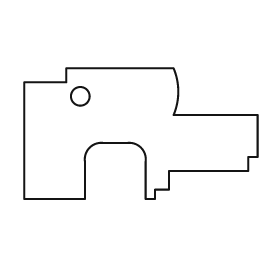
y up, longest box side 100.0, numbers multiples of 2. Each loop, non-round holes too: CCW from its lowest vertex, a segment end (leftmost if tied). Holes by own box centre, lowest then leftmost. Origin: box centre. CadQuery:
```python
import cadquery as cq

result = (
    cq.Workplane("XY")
    .moveTo(-50.0, -28.0)
    .lineTo(-24.0, -28.0)
    .lineTo(-24.0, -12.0)
    .threePointArc((-22.0, -6.0), (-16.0, -4.0))
    .lineTo(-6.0, -4.0)
    .threePointArc((0.0, -6.0), (2.0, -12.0))
    .lineTo(2.0, -28.0)
    .lineTo(6.0, -28.0)
    .lineTo(6.0, -24.0)
    .lineTo(12.0, -24.0)
    .lineTo(12.0, -16.0)
    .lineTo(46.0, -16.0)
    .lineTo(46.0, -10.0)
    .lineTo(50.0, -10.0)
    .lineTo(50.0, 8.0)
    .lineTo(14.0, 8.0)
    .threePointArc((16.0, 18.0), (14.0, 28.0))
    .lineTo(-32.0, 28.0)
    .lineTo(-32.0, 22.0)
    .lineTo(-50.0, 22.0)
    .close()
    .moveTo(-26.0, 16.0)
    .circle(4.0)
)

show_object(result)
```